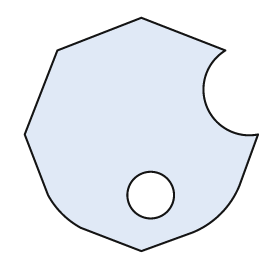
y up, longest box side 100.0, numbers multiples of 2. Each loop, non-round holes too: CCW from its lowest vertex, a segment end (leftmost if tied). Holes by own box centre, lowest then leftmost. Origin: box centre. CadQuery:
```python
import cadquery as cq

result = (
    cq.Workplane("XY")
    .moveTo(0.0, -50.0)
    .lineTo(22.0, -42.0)
    .threePointArc((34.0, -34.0), (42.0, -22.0))
    .lineTo(50.0, 0.0)
    .threePointArc((28.0, 12.0), (36.0, 36.0))
    .lineTo(0.0, 50.0)
    .lineTo(-36.0, 36.0)
    .lineTo(-50.0, 0.0)
    .lineTo(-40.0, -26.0)
    .threePointArc((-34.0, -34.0), (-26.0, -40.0))
    .close()
    .moveTo(4.0, -26.0)
    .circle(10.0)
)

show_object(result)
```